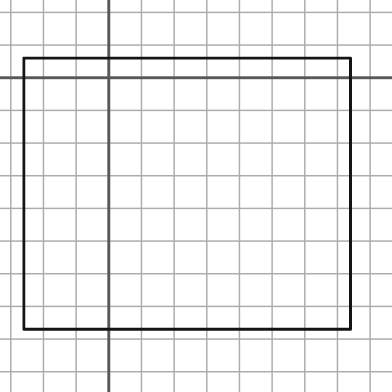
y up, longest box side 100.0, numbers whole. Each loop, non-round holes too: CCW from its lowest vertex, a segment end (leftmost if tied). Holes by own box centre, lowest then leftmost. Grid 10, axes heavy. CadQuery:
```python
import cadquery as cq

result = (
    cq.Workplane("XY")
    .moveTo(-26.0, -77.0)
    .lineTo(74.0, -77.0)
    .lineTo(74.0, 6.0)
    .lineTo(-26.0, 6.0)
    .close()
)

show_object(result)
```